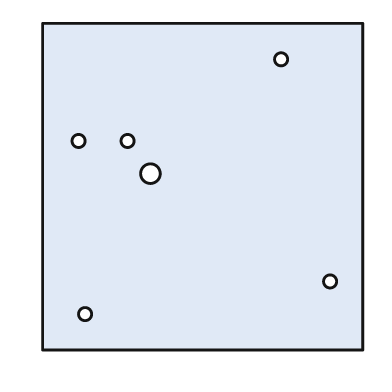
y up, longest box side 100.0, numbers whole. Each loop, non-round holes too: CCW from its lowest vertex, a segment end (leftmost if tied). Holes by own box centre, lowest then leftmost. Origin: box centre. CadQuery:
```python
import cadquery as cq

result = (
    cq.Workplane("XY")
    .moveTo(-49.0, -50.0)
    .lineTo(49.0, -50.0)
    .lineTo(49.0, 50.0)
    .lineTo(-49.0, 50.0)
    .close()
    .moveTo(-36.0, -39.0)
    .circle(2.0)
    .moveTo(39.0, -29.0)
    .circle(2.0)
    .moveTo(-16.0, 4.0)
    .circle(3.0)
    .moveTo(-38.0, 14.0)
    .circle(2.0)
    .moveTo(-23.0, 14.0)
    .circle(2.0)
    .moveTo(24.0, 39.0)
    .circle(2.0)
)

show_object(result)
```